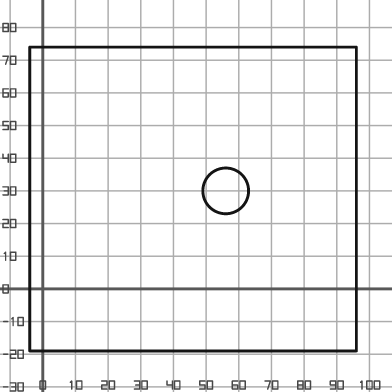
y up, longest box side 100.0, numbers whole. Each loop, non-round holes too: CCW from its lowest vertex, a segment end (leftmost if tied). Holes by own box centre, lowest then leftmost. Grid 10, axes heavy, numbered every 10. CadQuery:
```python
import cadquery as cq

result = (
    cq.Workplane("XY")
    .moveTo(-4.0, -19.0)
    .lineTo(96.0, -19.0)
    .lineTo(96.0, 74.0)
    .lineTo(-4.0, 74.0)
    .close()
    .moveTo(56.0, 30.0)
    .circle(7.0)
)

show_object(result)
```